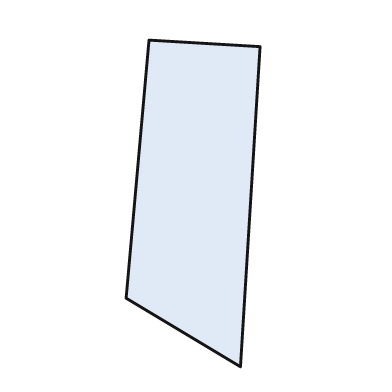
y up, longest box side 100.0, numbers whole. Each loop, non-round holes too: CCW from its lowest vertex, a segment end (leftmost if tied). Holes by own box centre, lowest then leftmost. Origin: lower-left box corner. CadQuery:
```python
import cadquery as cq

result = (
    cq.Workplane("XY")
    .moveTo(35.0, 0.0)
    .lineTo(41.0, 98.0)
    .lineTo(7.0, 100.0)
    .lineTo(0.0, 21.0)
    .close()
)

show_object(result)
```